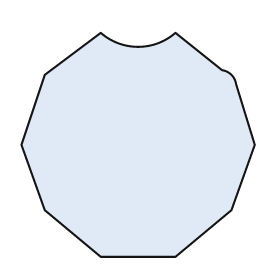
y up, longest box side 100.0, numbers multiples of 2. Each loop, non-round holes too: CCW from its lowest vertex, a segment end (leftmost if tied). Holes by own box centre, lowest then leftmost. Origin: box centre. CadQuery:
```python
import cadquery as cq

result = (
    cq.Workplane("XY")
    .moveTo(-16.0, -48.0)
    .lineTo(16.0, -48.0)
    .lineTo(40.0, -28.0)
    .lineTo(50.0, 0.0)
    .lineTo(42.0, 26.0)
    .threePointArc((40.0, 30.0), (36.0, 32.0))
    .lineTo(16.0, 48.0)
    .threePointArc((0.0, 42.0), (-16.0, 48.0))
    .lineTo(-40.0, 30.0)
    .lineTo(-50.0, 0.0)
    .lineTo(-40.0, -28.0)
    .close()
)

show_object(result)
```